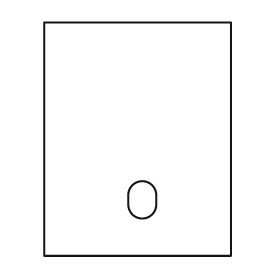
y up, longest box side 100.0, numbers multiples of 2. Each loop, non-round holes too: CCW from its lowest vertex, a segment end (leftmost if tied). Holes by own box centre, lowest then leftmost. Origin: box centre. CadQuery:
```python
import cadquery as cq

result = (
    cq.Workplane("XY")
    .moveTo(-40.0, -50.0)
    .lineTo(40.0, -50.0)
    .lineTo(40.0, 50.0)
    .lineTo(-40.0, 50.0)
    .close()
    .moveTo(-4.0, -28.0)
    .threePointArc((2.0, -34.0), (8.0, -28.0))
    .lineTo(8.0, -24.0)
    .threePointArc((2.0, -18.0), (-4.0, -24.0))
    .close()
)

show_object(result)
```